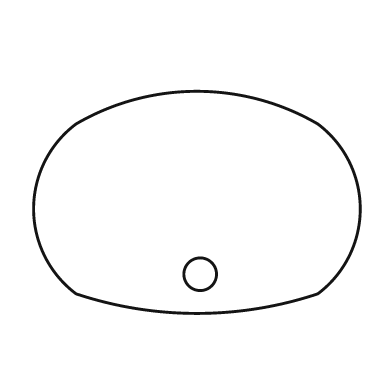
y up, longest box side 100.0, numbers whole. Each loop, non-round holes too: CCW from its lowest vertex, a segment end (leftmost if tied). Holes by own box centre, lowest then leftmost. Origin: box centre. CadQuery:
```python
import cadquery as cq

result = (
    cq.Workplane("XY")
    .moveTo(-37.0, -28.0)
    .threePointArc((0.0, -34.0), (37.0, -28.0))
    .threePointArc((50.0, -2.0), (37.0, 24.0))
    .threePointArc((0.0, 34.0), (-37.0, 24.0))
    .threePointArc((-50.0, -2.0), (-37.0, -28.0))
    .close()
    .moveTo(1.0, -22.0)
    .circle(5.0)
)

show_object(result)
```